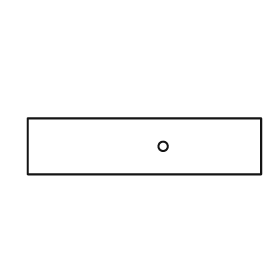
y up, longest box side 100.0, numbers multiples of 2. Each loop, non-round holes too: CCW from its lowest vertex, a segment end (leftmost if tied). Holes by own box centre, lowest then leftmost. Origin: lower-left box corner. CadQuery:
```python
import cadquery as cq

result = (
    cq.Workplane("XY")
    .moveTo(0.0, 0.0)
    .lineTo(100.0, 0.0)
    .lineTo(100.0, 24.0)
    .lineTo(0.0, 24.0)
    .close()
    .moveTo(58.0, 12.0)
    .circle(2.0)
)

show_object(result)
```